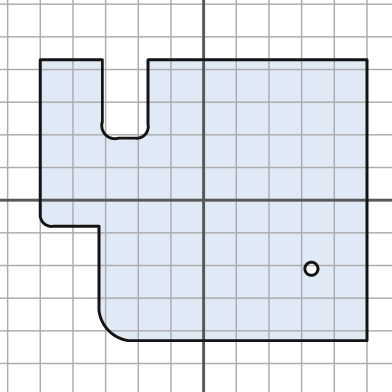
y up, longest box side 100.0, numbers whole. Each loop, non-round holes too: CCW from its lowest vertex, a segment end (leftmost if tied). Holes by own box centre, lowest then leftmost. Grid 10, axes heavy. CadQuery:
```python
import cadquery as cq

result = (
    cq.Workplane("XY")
    .moveTo(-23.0, -43.0)
    .lineTo(50.0, -43.0)
    .lineTo(50.0, 43.0)
    .lineTo(-17.0, 43.0)
    .lineTo(-17.0, 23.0)
    .threePointArc((-18.0, 20.0), (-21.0, 19.0))
    .lineTo(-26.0, 19.0)
    .threePointArc((-30.0, 20.0), (-31.0, 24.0))
    .lineTo(-31.0, 43.0)
    .lineTo(-50.0, 43.0)
    .lineTo(-50.0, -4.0)
    .threePointArc((-49.0, -7.0), (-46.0, -8.0))
    .lineTo(-32.0, -8.0)
    .lineTo(-32.0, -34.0)
    .threePointArc((-29.0, -40.0), (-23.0, -43.0))
    .close()
    .moveTo(33.0, -21.0)
    .circle(2.0)
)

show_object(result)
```